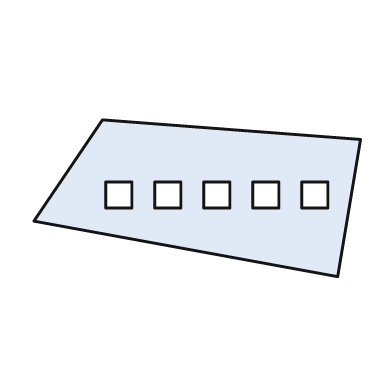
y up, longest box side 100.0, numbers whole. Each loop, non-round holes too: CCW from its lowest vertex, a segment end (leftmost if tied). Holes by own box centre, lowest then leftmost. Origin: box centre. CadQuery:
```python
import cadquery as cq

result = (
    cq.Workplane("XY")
    .moveTo(43.0, -24.0)
    .lineTo(50.0, 18.0)
    .lineTo(-29.0, 24.0)
    .lineTo(-50.0, -7.0)
    .close()
    .moveTo(-28.0, -3.0)
    .lineTo(-20.0, -3.0)
    .lineTo(-20.0, 5.0)
    .lineTo(-28.0, 5.0)
    .close()
    .moveTo(-13.0, -3.0)
    .lineTo(-5.0, -3.0)
    .lineTo(-5.0, 5.0)
    .lineTo(-13.0, 5.0)
    .close()
    .moveTo(2.0, -3.0)
    .lineTo(10.0, -3.0)
    .lineTo(10.0, 5.0)
    .lineTo(2.0, 5.0)
    .close()
    .moveTo(17.0, -3.0)
    .lineTo(25.0, -3.0)
    .lineTo(25.0, 5.0)
    .lineTo(17.0, 5.0)
    .close()
    .moveTo(32.0, -3.0)
    .lineTo(40.0, -3.0)
    .lineTo(40.0, 5.0)
    .lineTo(32.0, 5.0)
    .close()
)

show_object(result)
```